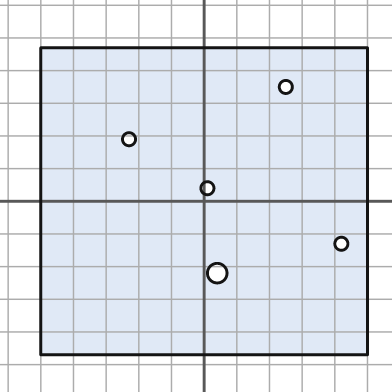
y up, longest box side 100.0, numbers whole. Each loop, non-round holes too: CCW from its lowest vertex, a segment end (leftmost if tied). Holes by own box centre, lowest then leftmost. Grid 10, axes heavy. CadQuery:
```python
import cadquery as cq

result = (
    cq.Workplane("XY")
    .moveTo(-50.0, -47.0)
    .lineTo(50.0, -47.0)
    .lineTo(50.0, 47.0)
    .lineTo(-50.0, 47.0)
    .close()
    .moveTo(4.0, -22.0)
    .circle(3.0)
    .moveTo(42.0, -13.0)
    .circle(2.0)
    .moveTo(1.0, 4.0)
    .circle(2.0)
    .moveTo(-23.0, 19.0)
    .circle(2.0)
    .moveTo(25.0, 35.0)
    .circle(2.0)
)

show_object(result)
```